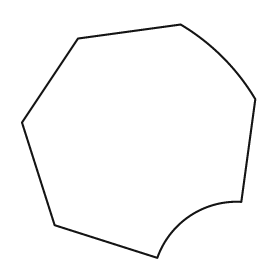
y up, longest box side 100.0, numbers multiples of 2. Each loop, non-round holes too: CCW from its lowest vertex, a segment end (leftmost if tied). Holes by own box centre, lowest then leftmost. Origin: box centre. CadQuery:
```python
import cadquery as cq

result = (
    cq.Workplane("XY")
    .moveTo(8.0, -50.0)
    .threePointArc((22.0, -32.0), (44.0, -26.0))
    .lineTo(50.0, 18.0)
    .threePointArc((36.0, 36.0), (18.0, 50.0))
    .lineTo(-26.0, 44.0)
    .lineTo(-50.0, 8.0)
    .lineTo(-36.0, -36.0)
    .close()
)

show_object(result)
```